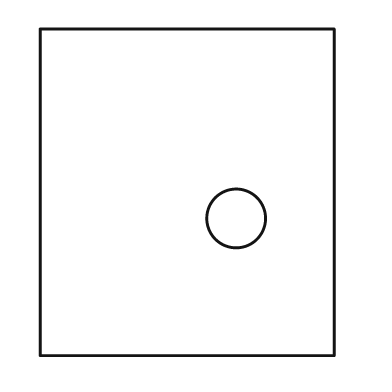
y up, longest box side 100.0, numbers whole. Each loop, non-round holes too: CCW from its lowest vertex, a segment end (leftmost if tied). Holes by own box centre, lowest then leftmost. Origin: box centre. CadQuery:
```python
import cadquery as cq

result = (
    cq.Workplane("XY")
    .moveTo(-45.0, -50.0)
    .lineTo(45.0, -50.0)
    .lineTo(45.0, 50.0)
    .lineTo(-45.0, 50.0)
    .close()
    .moveTo(15.0, -8.0)
    .circle(9.0)
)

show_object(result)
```